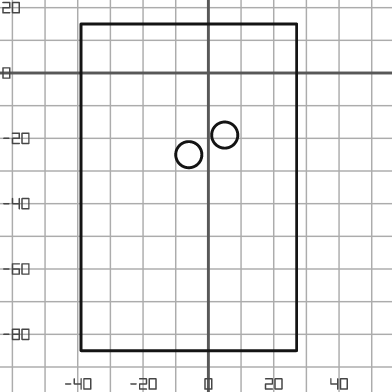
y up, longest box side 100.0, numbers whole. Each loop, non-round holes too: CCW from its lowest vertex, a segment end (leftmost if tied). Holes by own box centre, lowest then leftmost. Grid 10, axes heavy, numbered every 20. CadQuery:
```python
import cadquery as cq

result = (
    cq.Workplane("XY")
    .moveTo(-39.0, -85.0)
    .lineTo(27.0, -85.0)
    .lineTo(27.0, 15.0)
    .lineTo(-39.0, 15.0)
    .close()
    .moveTo(-6.0, -25.0)
    .circle(4.0)
    .moveTo(5.0, -19.0)
    .circle(4.0)
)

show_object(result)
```